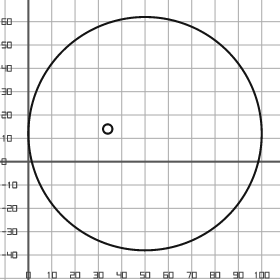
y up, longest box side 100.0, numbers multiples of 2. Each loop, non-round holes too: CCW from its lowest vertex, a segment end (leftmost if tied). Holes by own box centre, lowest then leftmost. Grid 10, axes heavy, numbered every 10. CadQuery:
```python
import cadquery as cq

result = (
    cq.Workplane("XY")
    .moveTo(50.0, 12.0)
    .circle(50.0)
    .moveTo(34.0, 14.0)
    .circle(2.0)
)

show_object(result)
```